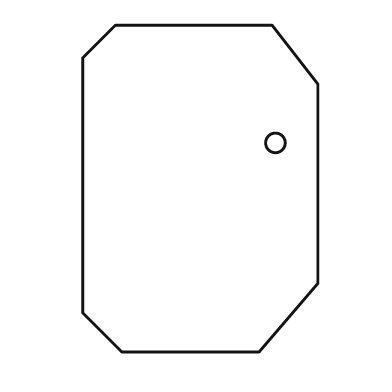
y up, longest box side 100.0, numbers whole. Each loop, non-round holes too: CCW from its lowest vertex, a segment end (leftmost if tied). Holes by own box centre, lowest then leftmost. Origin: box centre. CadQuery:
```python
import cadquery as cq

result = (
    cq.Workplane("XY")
    .moveTo(-24.0, -50.0)
    .lineTo(18.0, -50.0)
    .lineTo(36.0, -29.0)
    .lineTo(36.0, 32.0)
    .lineTo(22.0, 50.0)
    .lineTo(-26.0, 50.0)
    .lineTo(-36.0, 40.0)
    .lineTo(-36.0, -38.0)
    .close()
    .moveTo(23.0, 14.0)
    .circle(3.0)
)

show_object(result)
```